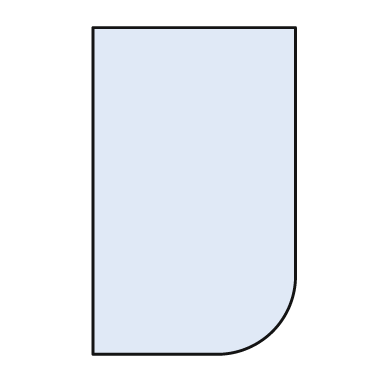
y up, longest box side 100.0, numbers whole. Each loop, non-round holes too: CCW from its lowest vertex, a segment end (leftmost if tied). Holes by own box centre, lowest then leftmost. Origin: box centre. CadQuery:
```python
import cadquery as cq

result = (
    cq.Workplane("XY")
    .moveTo(-31.0, -50.0)
    .lineTo(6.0, -50.0)
    .threePointArc((24.0, -43.0), (31.0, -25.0))
    .lineTo(31.0, 50.0)
    .lineTo(-31.0, 50.0)
    .close()
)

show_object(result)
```